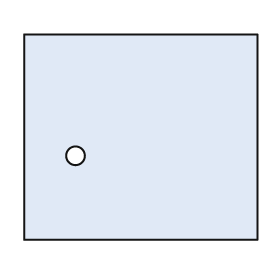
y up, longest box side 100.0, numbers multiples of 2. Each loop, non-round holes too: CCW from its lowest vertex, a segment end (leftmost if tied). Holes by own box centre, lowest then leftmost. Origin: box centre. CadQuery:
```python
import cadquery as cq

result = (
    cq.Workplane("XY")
    .moveTo(-50.0, -44.0)
    .lineTo(50.0, -44.0)
    .lineTo(50.0, 44.0)
    .lineTo(-50.0, 44.0)
    .close()
    .moveTo(-28.0, -8.0)
    .circle(4.0)
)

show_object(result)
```